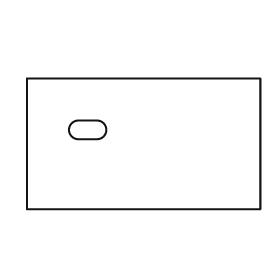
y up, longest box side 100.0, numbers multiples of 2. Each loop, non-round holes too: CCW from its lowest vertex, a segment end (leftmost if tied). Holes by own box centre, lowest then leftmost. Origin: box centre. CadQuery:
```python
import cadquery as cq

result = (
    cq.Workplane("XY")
    .moveTo(-50.0, -28.0)
    .lineTo(50.0, -28.0)
    .lineTo(50.0, 28.0)
    .lineTo(-50.0, 28.0)
    .close()
    .moveTo(-28.0, 2.0)
    .lineTo(-20.0, 2.0)
    .threePointArc((-16.0, 6.0), (-20.0, 10.0))
    .lineTo(-28.0, 10.0)
    .threePointArc((-32.0, 6.0), (-28.0, 2.0))
    .close()
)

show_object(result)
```